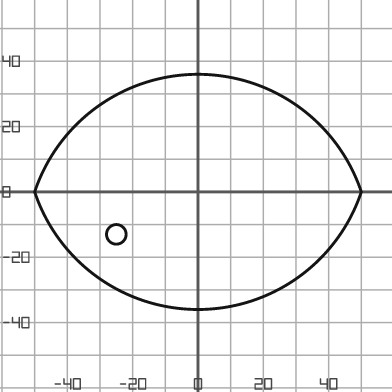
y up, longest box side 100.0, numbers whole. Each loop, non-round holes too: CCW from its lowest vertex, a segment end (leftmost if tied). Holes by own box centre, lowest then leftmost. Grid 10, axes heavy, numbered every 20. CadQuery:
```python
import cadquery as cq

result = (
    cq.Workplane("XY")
    .moveTo(-50.0, 0.0)
    .threePointArc((0.0, -36.0), (50.0, 0.0))
    .threePointArc((0.0, 36.0), (-50.0, 0.0))
    .close()
    .moveTo(-25.0, -13.0)
    .circle(3.0)
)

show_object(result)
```